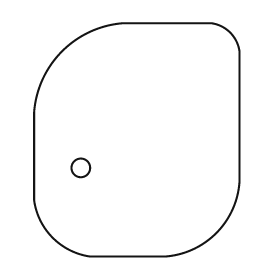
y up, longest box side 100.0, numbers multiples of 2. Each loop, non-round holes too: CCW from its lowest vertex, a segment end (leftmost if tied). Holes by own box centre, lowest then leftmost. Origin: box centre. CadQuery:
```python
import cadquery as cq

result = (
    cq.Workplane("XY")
    .moveTo(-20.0, -50.0)
    .lineTo(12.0, -50.0)
    .threePointArc((34.0, -40.0), (44.0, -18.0))
    .lineTo(44.0, 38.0)
    .threePointArc((40.0, 46.0), (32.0, 50.0))
    .lineTo(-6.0, 50.0)
    .threePointArc((-32.0, 38.0), (-44.0, 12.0))
    .lineTo(-44.0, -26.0)
    .threePointArc((-36.0, -42.0), (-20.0, -50.0))
    .close()
    .moveTo(-24.0, -12.0)
    .circle(4.0)
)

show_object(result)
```